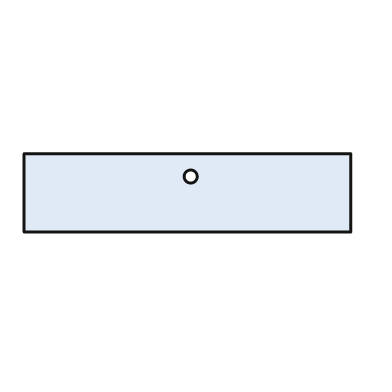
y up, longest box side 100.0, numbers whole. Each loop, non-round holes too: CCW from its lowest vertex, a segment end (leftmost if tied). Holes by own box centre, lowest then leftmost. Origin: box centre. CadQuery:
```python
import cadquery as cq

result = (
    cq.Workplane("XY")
    .moveTo(-50.0, -12.0)
    .lineTo(50.0, -12.0)
    .lineTo(50.0, 12.0)
    .lineTo(-50.0, 12.0)
    .close()
    .moveTo(1.0, 5.0)
    .circle(2.0)
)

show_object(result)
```